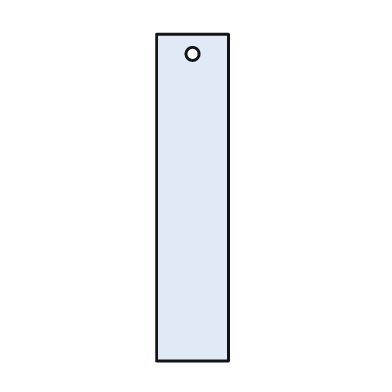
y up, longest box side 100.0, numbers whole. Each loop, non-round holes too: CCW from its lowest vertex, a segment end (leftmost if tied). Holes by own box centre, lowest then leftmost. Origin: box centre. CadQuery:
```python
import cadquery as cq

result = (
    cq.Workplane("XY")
    .moveTo(-11.0, -50.0)
    .lineTo(11.0, -50.0)
    .lineTo(11.0, 50.0)
    .lineTo(-11.0, 50.0)
    .close()
    .moveTo(0.0, 44.0)
    .circle(2.0)
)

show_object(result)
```